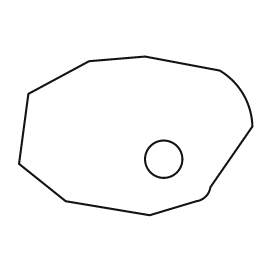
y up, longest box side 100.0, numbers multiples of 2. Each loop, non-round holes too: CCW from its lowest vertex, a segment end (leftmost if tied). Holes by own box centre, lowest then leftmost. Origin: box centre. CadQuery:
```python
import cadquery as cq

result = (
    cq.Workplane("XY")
    .moveTo(6.0, -34.0)
    .lineTo(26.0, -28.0)
    .threePointArc((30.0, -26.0), (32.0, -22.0))
    .lineTo(50.0, 4.0)
    .threePointArc((46.0, 18.0), (36.0, 28.0))
    .lineTo(4.0, 34.0)
    .lineTo(-20.0, 32.0)
    .lineTo(-46.0, 18.0)
    .lineTo(-50.0, -12.0)
    .lineTo(-30.0, -28.0)
    .close()
    .moveTo(12.0, -10.0)
    .circle(8.0)
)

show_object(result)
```